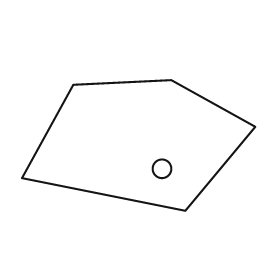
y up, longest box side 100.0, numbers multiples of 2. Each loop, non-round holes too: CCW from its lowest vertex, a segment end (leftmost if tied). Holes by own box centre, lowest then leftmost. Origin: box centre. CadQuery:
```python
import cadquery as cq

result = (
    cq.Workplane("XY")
    .moveTo(20.0, -28.0)
    .lineTo(50.0, 8.0)
    .lineTo(14.0, 28.0)
    .lineTo(-28.0, 26.0)
    .lineTo(-50.0, -14.0)
    .close()
    .moveTo(10.0, -10.0)
    .circle(4.0)
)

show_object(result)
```